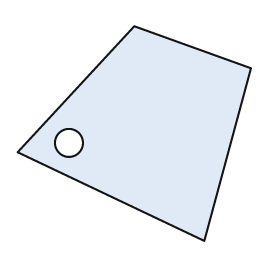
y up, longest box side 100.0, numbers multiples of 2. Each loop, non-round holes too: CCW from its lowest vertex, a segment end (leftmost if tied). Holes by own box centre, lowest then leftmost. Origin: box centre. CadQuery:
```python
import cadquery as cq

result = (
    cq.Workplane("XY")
    .moveTo(30.0, -46.0)
    .lineTo(50.0, 28.0)
    .lineTo(0.0, 46.0)
    .lineTo(-50.0, -8.0)
    .close()
    .moveTo(-28.0, -4.0)
    .circle(6.0)
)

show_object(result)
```